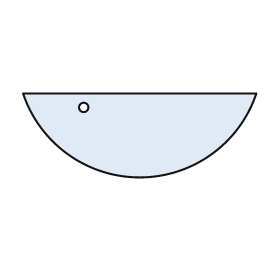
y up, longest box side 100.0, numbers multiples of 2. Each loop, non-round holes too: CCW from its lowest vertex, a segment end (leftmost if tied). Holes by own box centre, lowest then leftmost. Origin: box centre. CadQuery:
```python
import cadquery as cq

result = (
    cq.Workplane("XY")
    .moveTo(-50.0, 18.0)
    .threePointArc((0.0, -18.0), (50.0, 18.0))
    .close()
    .moveTo(-24.0, 12.0)
    .circle(2.0)
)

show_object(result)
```